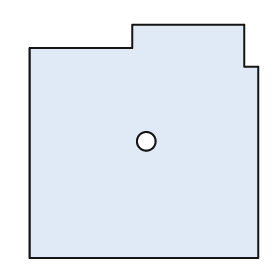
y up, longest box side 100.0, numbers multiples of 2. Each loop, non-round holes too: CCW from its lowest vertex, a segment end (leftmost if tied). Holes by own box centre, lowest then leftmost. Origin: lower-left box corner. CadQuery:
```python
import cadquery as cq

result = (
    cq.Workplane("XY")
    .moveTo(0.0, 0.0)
    .lineTo(98.0, 0.0)
    .lineTo(98.0, 82.0)
    .lineTo(92.0, 82.0)
    .lineTo(92.0, 100.0)
    .lineTo(44.0, 100.0)
    .lineTo(44.0, 90.0)
    .lineTo(0.0, 90.0)
    .close()
    .moveTo(50.0, 50.0)
    .circle(4.0)
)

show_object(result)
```